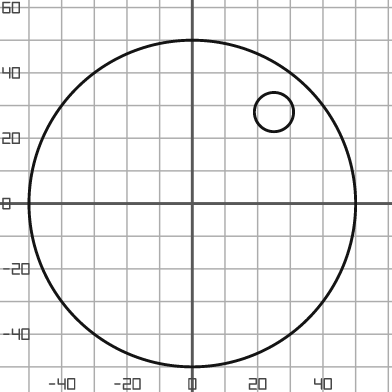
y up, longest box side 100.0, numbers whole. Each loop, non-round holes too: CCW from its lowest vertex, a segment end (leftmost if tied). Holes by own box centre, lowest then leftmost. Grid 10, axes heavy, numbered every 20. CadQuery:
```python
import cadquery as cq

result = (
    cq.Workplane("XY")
    .moveTo(0.0, 0.0)
    .circle(50.0)
    .moveTo(25.0, 28.0)
    .circle(6.0)
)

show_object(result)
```